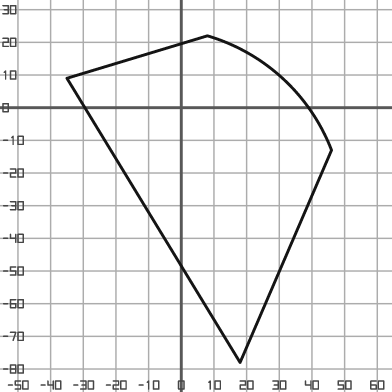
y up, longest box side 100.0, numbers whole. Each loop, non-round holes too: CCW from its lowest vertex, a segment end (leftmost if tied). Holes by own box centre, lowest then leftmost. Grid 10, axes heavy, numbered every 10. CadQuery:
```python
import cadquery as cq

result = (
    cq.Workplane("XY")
    .moveTo(18.0, -78.0)
    .lineTo(46.0, -13.0)
    .threePointArc((31.0, 9.0), (8.0, 22.0))
    .lineTo(-35.0, 9.0)
    .close()
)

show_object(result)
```